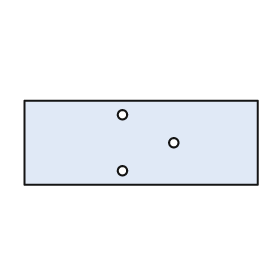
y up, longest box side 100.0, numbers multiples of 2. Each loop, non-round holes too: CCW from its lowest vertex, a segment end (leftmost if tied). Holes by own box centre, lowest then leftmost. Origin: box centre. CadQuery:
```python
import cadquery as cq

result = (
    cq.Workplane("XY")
    .moveTo(-50.0, -18.0)
    .lineTo(50.0, -18.0)
    .lineTo(50.0, 18.0)
    .lineTo(-50.0, 18.0)
    .close()
    .moveTo(-8.0, -12.0)
    .circle(2.0)
    .moveTo(14.0, 0.0)
    .circle(2.0)
    .moveTo(-8.0, 12.0)
    .circle(2.0)
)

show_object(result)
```